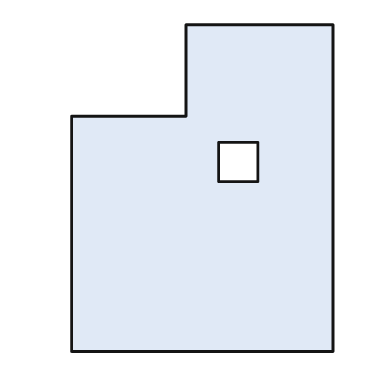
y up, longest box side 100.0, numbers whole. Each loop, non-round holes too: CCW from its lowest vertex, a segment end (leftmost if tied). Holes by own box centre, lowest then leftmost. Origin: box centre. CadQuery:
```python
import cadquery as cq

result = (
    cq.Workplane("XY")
    .moveTo(-40.0, -50.0)
    .lineTo(40.0, -50.0)
    .lineTo(40.0, 50.0)
    .lineTo(-5.0, 50.0)
    .lineTo(-5.0, 22.0)
    .lineTo(-40.0, 22.0)
    .close()
    .moveTo(5.0, 2.0)
    .lineTo(17.0, 2.0)
    .lineTo(17.0, 14.0)
    .lineTo(5.0, 14.0)
    .close()
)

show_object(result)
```